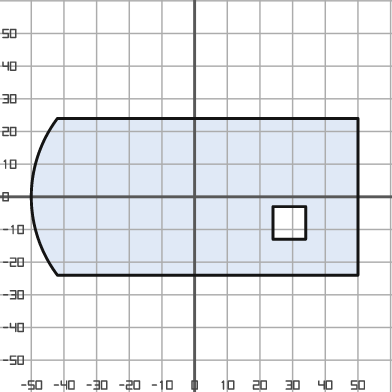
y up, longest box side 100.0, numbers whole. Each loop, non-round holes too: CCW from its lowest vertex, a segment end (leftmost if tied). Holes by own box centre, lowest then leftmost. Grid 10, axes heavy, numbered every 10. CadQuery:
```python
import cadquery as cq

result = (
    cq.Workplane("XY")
    .moveTo(-42.0, -24.0)
    .lineTo(50.0, -24.0)
    .lineTo(50.0, 24.0)
    .lineTo(-42.0, 24.0)
    .threePointArc((-50.0, 0.0), (-42.0, -24.0))
    .close()
    .moveTo(24.0, -13.0)
    .lineTo(34.0, -13.0)
    .lineTo(34.0, -3.0)
    .lineTo(24.0, -3.0)
    .close()
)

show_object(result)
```